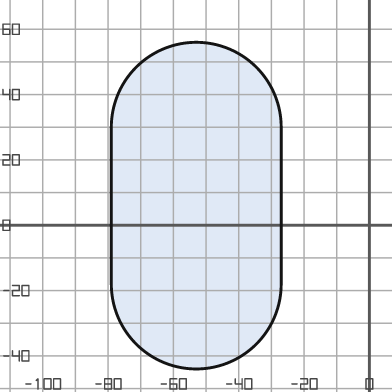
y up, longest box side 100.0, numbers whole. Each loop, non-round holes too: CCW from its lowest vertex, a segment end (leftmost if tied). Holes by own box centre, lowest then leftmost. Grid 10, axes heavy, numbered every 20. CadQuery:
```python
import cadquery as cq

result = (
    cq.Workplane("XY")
    .moveTo(-79.0, -18.0)
    .threePointArc((-53.0, -44.0), (-27.0, -18.0))
    .lineTo(-27.0, 30.0)
    .threePointArc((-53.0, 56.0), (-79.0, 30.0))
    .close()
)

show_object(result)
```